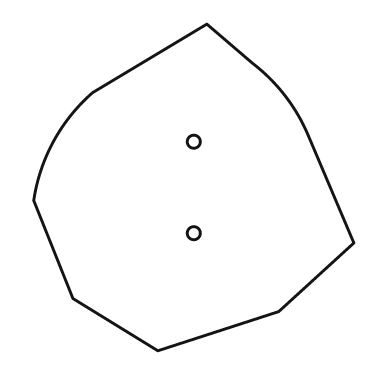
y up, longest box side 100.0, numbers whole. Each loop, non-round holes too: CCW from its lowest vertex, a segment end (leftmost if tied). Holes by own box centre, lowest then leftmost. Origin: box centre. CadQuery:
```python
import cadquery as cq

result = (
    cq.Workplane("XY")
    .moveTo(-11.0, -50.0)
    .lineTo(26.0, -38.0)
    .lineTo(49.0, -17.0)
    .lineTo(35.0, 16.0)
    .threePointArc((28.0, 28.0), (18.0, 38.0))
    .lineTo(4.0, 50.0)
    .lineTo(-31.0, 29.0)
    .threePointArc((-43.0, 14.0), (-49.0, -4.0))
    .lineTo(-37.0, -34.0)
    .close()
    .moveTo(0.0, -14.0)
    .circle(2.0)
    .moveTo(0.0, 14.0)
    .circle(2.0)
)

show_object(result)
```